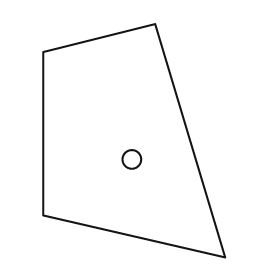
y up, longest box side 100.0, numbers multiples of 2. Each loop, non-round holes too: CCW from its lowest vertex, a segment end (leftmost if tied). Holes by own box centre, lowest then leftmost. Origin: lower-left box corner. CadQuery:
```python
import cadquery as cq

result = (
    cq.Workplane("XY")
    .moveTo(78.0, 0.0)
    .lineTo(48.0, 100.0)
    .lineTo(0.0, 88.0)
    .lineTo(0.0, 18.0)
    .close()
    .moveTo(38.0, 42.0)
    .circle(4.0)
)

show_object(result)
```